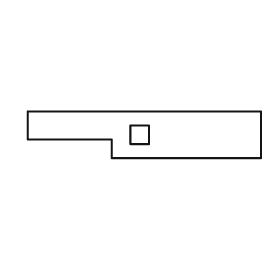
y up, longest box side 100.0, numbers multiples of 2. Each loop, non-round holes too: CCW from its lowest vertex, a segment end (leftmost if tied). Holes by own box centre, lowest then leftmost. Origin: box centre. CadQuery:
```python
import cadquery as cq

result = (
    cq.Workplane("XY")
    .moveTo(-14.0, -10.0)
    .lineTo(50.0, -10.0)
    .lineTo(50.0, 10.0)
    .lineTo(-50.0, 10.0)
    .lineTo(-50.0, -2.0)
    .lineTo(-14.0, -2.0)
    .close()
    .moveTo(-6.0, -4.0)
    .lineTo(2.0, -4.0)
    .lineTo(2.0, 4.0)
    .lineTo(-6.0, 4.0)
    .close()
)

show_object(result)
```